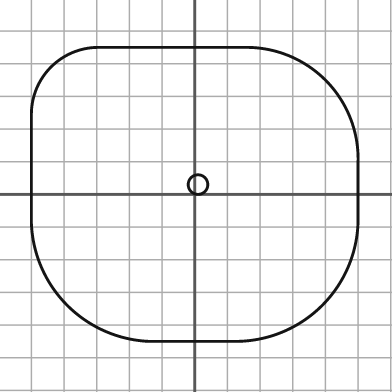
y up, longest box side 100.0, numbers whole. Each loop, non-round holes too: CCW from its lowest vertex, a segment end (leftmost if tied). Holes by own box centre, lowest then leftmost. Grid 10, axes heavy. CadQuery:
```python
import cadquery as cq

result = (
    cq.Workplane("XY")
    .moveTo(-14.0, -45.0)
    .lineTo(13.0, -45.0)
    .threePointArc((39.0, -34.0), (50.0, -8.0))
    .lineTo(50.0, 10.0)
    .threePointArc((40.0, 35.0), (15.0, 45.0))
    .lineTo(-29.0, 45.0)
    .threePointArc((-44.0, 39.0), (-50.0, 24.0))
    .lineTo(-50.0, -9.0)
    .threePointArc((-39.0, -34.0), (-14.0, -45.0))
    .close()
    .moveTo(1.0, 3.0)
    .circle(3.0)
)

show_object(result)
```